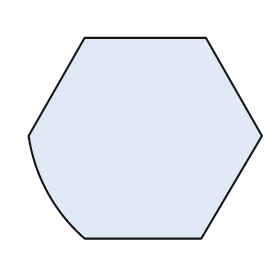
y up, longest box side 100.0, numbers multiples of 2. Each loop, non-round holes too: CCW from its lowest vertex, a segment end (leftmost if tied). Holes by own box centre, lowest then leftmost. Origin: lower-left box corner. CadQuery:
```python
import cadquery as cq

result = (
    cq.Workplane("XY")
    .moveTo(24.0, 0.0)
    .lineTo(74.0, 0.0)
    .lineTo(100.0, 44.0)
    .lineTo(76.0, 86.0)
    .lineTo(24.0, 86.0)
    .lineTo(0.0, 44.0)
    .threePointArc((8.0, 20.0), (24.0, 0.0))
    .close()
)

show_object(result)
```